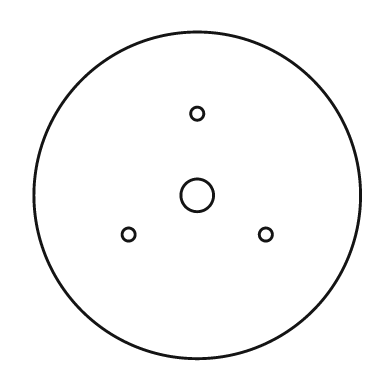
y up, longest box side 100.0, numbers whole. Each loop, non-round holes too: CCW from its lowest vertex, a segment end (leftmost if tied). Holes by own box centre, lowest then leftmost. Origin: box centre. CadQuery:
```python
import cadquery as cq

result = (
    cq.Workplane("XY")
    .moveTo(0.0, 0.0)
    .circle(50.0)
    .moveTo(-21.0, -12.0)
    .circle(2.0)
    .moveTo(21.0, -12.0)
    .circle(2.0)
    .moveTo(0.0, 0.0)
    .circle(5.0)
    .moveTo(0.0, 25.0)
    .circle(2.0)
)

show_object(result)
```